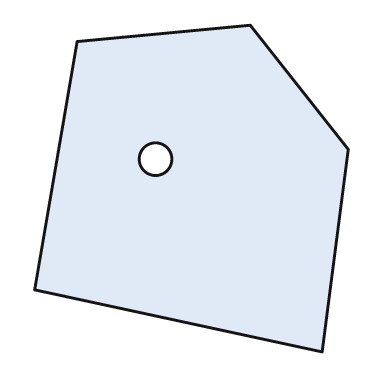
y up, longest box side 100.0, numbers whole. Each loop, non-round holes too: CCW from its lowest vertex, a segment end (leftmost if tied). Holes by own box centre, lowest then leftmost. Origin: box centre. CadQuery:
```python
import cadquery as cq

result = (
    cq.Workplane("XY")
    .moveTo(40.0, -50.0)
    .lineTo(48.0, 12.0)
    .lineTo(18.0, 50.0)
    .lineTo(-35.0, 45.0)
    .lineTo(-48.0, -31.0)
    .close()
    .moveTo(-11.0, 9.0)
    .circle(5.0)
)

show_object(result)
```